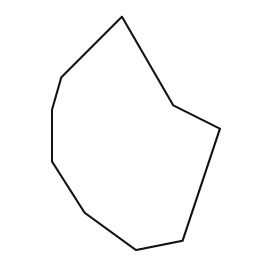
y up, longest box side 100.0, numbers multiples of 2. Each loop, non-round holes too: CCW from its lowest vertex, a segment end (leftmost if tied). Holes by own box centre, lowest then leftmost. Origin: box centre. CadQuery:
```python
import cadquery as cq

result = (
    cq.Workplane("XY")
    .moveTo(0.0, -50.0)
    .lineTo(20.0, -46.0)
    .lineTo(36.0, 2.0)
    .lineTo(16.0, 12.0)
    .lineTo(-6.0, 50.0)
    .lineTo(-32.0, 24.0)
    .lineTo(-36.0, 10.0)
    .lineTo(-36.0, -12.0)
    .lineTo(-22.0, -34.0)
    .close()
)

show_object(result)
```